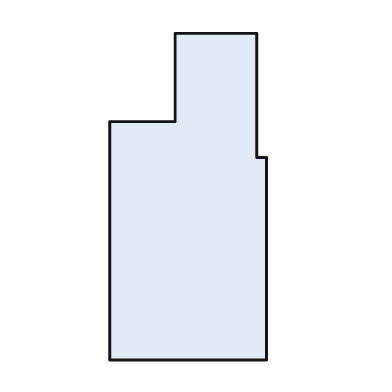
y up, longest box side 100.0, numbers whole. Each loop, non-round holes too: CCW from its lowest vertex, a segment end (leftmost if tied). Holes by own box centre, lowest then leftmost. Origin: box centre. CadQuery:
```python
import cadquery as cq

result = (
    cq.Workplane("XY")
    .moveTo(-24.0, -50.0)
    .lineTo(24.0, -50.0)
    .lineTo(24.0, 12.0)
    .lineTo(21.0, 12.0)
    .lineTo(21.0, 50.0)
    .lineTo(-4.0, 50.0)
    .lineTo(-4.0, 23.0)
    .lineTo(-24.0, 23.0)
    .close()
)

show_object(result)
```